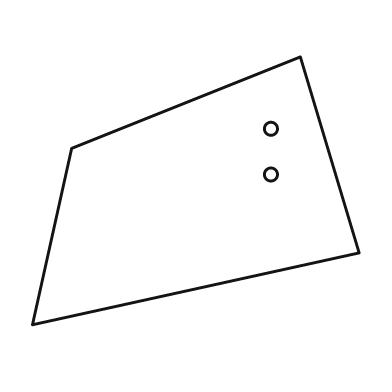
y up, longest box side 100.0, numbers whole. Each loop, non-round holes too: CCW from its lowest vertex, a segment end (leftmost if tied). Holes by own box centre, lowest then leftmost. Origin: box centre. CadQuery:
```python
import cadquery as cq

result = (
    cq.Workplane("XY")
    .moveTo(-50.0, -41.0)
    .lineTo(50.0, -19.0)
    .lineTo(32.0, 41.0)
    .lineTo(-38.0, 13.0)
    .close()
    .moveTo(23.0, 5.0)
    .circle(2.0)
    .moveTo(23.0, 19.0)
    .circle(2.0)
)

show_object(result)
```